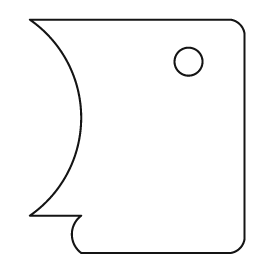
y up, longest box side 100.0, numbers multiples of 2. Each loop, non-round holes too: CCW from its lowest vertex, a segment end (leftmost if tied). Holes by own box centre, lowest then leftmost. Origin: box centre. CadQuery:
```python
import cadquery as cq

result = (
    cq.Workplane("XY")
    .moveTo(-24.0, -50.0)
    .lineTo(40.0, -50.0)
    .threePointArc((44.0, -48.0), (46.0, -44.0))
    .lineTo(46.0, 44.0)
    .threePointArc((44.0, 48.0), (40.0, 50.0))
    .lineTo(-46.0, 50.0)
    .threePointArc((-24.0, 8.0), (-46.0, -34.0))
    .lineTo(-24.0, -34.0)
    .threePointArc((-28.0, -42.0), (-24.0, -50.0))
    .close()
    .moveTo(22.0, 32.0)
    .circle(6.0)
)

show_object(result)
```